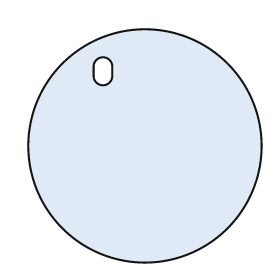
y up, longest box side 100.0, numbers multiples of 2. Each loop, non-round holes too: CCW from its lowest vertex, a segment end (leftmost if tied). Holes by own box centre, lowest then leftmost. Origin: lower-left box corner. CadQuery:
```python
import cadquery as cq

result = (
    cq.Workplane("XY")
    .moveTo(50.0, 50.0)
    .circle(50.0)
    .moveTo(28.0, 80.0)
    .threePointArc((32.0, 76.0), (36.0, 80.0))
    .lineTo(36.0, 84.0)
    .threePointArc((32.0, 88.0), (28.0, 84.0))
    .close()
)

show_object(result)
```